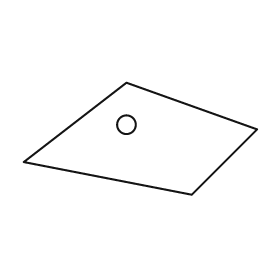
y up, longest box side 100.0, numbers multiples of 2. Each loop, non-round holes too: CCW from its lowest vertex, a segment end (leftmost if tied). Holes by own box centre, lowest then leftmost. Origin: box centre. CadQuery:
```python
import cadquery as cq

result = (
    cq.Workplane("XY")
    .moveTo(22.0, -24.0)
    .lineTo(50.0, 4.0)
    .lineTo(-6.0, 24.0)
    .lineTo(-50.0, -10.0)
    .close()
    .moveTo(-6.0, 6.0)
    .circle(4.0)
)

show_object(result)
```